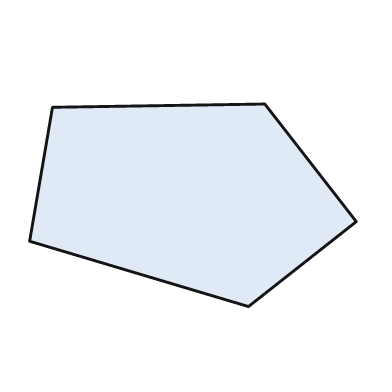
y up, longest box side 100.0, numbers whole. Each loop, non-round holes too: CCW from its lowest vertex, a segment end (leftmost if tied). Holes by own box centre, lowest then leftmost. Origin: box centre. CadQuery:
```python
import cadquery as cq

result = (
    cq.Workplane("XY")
    .moveTo(17.0, -31.0)
    .lineTo(50.0, -5.0)
    .lineTo(22.0, 31.0)
    .lineTo(-43.0, 30.0)
    .lineTo(-50.0, -11.0)
    .close()
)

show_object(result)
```